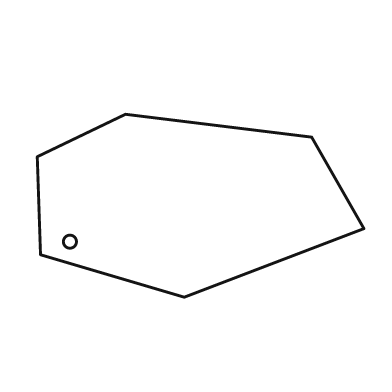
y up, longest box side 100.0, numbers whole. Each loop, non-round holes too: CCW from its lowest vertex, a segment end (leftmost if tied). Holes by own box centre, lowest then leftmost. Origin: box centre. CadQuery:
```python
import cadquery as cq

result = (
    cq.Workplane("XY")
    .moveTo(-5.0, -28.0)
    .lineTo(50.0, -7.0)
    .lineTo(34.0, 21.0)
    .lineTo(-23.0, 28.0)
    .lineTo(-50.0, 15.0)
    .lineTo(-49.0, -15.0)
    .close()
    .moveTo(-40.0, -11.0)
    .circle(2.0)
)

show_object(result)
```